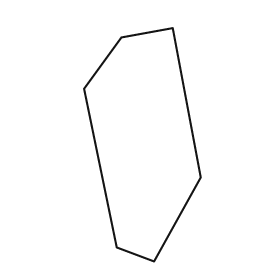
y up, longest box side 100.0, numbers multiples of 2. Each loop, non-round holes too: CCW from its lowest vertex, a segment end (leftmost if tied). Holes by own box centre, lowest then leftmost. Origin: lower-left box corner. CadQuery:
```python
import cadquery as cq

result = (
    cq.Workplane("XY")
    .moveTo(30.0, 0.0)
    .lineTo(50.0, 36.0)
    .lineTo(38.0, 100.0)
    .lineTo(16.0, 96.0)
    .lineTo(0.0, 74.0)
    .lineTo(14.0, 6.0)
    .close()
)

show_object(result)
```